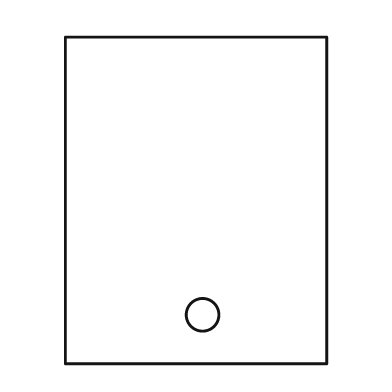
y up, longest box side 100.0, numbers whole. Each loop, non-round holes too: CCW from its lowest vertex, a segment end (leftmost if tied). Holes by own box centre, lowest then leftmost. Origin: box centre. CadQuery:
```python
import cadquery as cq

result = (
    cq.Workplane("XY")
    .moveTo(-40.0, -50.0)
    .lineTo(40.0, -50.0)
    .lineTo(40.0, 50.0)
    .lineTo(-40.0, 50.0)
    .close()
    .moveTo(2.0, -35.0)
    .circle(5.0)
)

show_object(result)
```